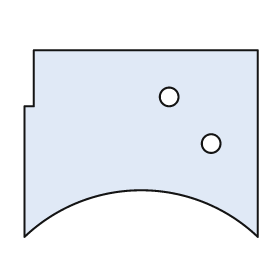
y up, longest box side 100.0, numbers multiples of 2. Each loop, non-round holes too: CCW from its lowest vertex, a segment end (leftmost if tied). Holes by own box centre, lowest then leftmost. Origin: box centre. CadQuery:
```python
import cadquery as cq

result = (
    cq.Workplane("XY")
    .moveTo(-50.0, -40.0)
    .threePointArc((0.0, -20.0), (50.0, -40.0))
    .lineTo(50.0, 40.0)
    .lineTo(-46.0, 40.0)
    .lineTo(-46.0, 16.0)
    .lineTo(-50.0, 16.0)
    .close()
    .moveTo(30.0, 0.0)
    .circle(4.0)
    .moveTo(12.0, 20.0)
    .circle(4.0)
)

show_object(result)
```